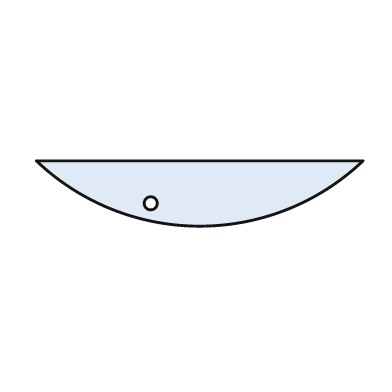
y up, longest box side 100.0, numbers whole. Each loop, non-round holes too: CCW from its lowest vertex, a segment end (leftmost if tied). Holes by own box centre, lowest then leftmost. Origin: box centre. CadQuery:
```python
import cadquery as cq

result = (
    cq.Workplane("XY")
    .moveTo(-50.0, 10.0)
    .threePointArc((0.0, -10.0), (50.0, 10.0))
    .close()
    .moveTo(-15.0, -3.0)
    .circle(2.0)
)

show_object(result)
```